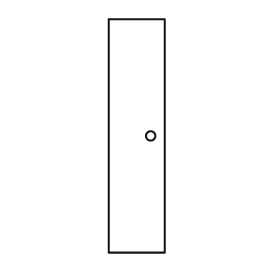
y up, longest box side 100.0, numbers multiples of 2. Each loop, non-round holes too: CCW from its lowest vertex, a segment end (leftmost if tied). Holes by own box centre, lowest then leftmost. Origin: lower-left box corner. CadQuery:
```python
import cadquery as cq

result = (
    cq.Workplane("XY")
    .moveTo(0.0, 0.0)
    .lineTo(24.0, 0.0)
    .lineTo(24.0, 100.0)
    .lineTo(0.0, 100.0)
    .close()
    .moveTo(18.0, 50.0)
    .circle(2.0)
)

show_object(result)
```